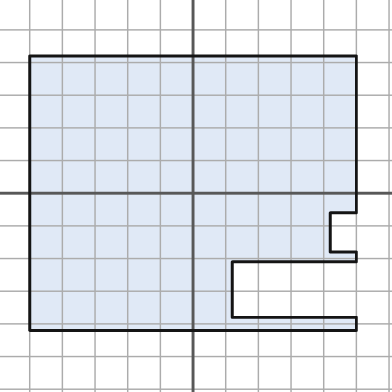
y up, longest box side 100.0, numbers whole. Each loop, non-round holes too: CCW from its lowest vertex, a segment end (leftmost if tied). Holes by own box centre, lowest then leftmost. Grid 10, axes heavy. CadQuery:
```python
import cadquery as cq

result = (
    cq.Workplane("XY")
    .moveTo(-50.0, -42.0)
    .lineTo(50.0, -42.0)
    .lineTo(50.0, -38.0)
    .lineTo(12.0, -38.0)
    .lineTo(12.0, -21.0)
    .lineTo(50.0, -21.0)
    .lineTo(50.0, -18.0)
    .lineTo(42.0, -18.0)
    .lineTo(42.0, -6.0)
    .lineTo(50.0, -6.0)
    .lineTo(50.0, 42.0)
    .lineTo(-50.0, 42.0)
    .close()
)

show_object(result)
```